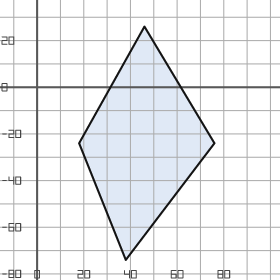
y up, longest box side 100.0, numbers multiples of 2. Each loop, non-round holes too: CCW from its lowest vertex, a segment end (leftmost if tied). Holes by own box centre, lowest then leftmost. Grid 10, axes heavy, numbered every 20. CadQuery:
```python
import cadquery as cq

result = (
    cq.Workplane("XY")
    .moveTo(38.0, -74.0)
    .lineTo(76.0, -24.0)
    .lineTo(46.0, 26.0)
    .lineTo(18.0, -24.0)
    .close()
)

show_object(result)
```